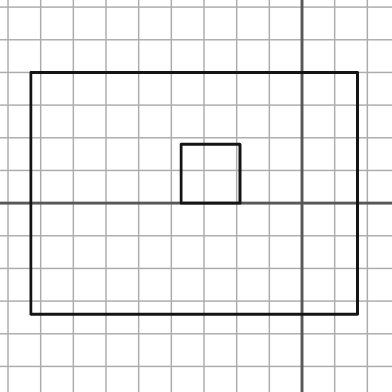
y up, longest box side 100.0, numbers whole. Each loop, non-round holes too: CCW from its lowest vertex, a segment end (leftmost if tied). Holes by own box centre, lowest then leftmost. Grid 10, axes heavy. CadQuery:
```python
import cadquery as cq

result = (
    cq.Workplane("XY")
    .moveTo(-83.0, -34.0)
    .lineTo(17.0, -34.0)
    .lineTo(17.0, 40.0)
    .lineTo(-83.0, 40.0)
    .close()
    .moveTo(-37.0, 0.0)
    .lineTo(-19.0, 0.0)
    .lineTo(-19.0, 18.0)
    .lineTo(-37.0, 18.0)
    .close()
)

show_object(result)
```